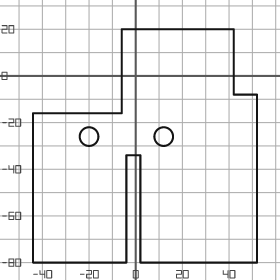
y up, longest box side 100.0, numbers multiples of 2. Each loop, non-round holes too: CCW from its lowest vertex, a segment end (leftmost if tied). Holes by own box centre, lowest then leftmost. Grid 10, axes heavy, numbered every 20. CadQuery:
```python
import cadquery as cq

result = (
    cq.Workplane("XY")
    .moveTo(-44.0, -80.0)
    .lineTo(-4.0, -80.0)
    .lineTo(-4.0, -34.0)
    .lineTo(2.0, -34.0)
    .lineTo(2.0, -80.0)
    .lineTo(52.0, -80.0)
    .lineTo(52.0, -8.0)
    .lineTo(42.0, -8.0)
    .lineTo(42.0, 20.0)
    .lineTo(-6.0, 20.0)
    .lineTo(-6.0, -16.0)
    .lineTo(-44.0, -16.0)
    .close()
    .moveTo(-20.0, -26.0)
    .circle(4.0)
    .moveTo(12.0, -26.0)
    .circle(4.0)
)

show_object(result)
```